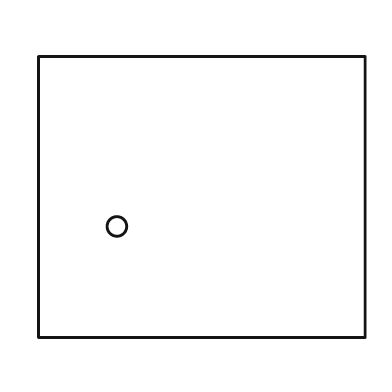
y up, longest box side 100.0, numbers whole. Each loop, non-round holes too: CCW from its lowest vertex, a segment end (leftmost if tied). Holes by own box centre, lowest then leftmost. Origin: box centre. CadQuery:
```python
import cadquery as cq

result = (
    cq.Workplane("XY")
    .moveTo(-50.0, -43.0)
    .lineTo(50.0, -43.0)
    .lineTo(50.0, 43.0)
    .lineTo(-50.0, 43.0)
    .close()
    .moveTo(-26.0, -9.0)
    .circle(3.0)
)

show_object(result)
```